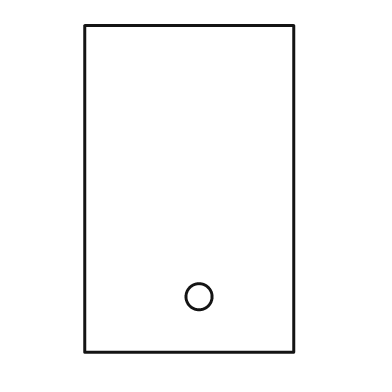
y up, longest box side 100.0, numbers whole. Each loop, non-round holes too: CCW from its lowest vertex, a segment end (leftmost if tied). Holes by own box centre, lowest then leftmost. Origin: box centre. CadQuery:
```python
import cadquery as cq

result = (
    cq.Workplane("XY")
    .moveTo(-32.0, -50.0)
    .lineTo(32.0, -50.0)
    .lineTo(32.0, 50.0)
    .lineTo(-32.0, 50.0)
    .close()
    .moveTo(3.0, -33.0)
    .circle(4.0)
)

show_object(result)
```